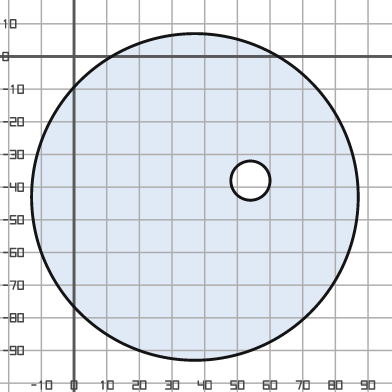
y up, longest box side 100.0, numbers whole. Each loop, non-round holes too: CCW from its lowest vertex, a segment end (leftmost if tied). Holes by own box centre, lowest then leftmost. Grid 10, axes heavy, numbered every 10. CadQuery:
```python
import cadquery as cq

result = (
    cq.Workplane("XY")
    .moveTo(37.0, -43.0)
    .circle(50.0)
    .moveTo(54.0, -38.0)
    .circle(6.0)
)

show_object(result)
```